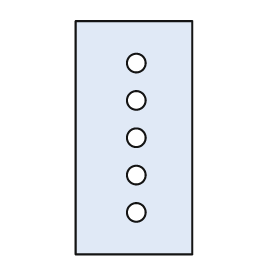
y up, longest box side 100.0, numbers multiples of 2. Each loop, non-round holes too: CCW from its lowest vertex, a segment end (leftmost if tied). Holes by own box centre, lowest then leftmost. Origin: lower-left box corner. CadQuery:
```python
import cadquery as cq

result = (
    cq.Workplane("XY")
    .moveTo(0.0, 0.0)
    .lineTo(50.0, 0.0)
    .lineTo(50.0, 100.0)
    .lineTo(0.0, 100.0)
    .close()
    .moveTo(26.0, 18.0)
    .circle(4.0)
    .moveTo(26.0, 34.0)
    .circle(4.0)
    .moveTo(26.0, 50.0)
    .circle(4.0)
    .moveTo(26.0, 66.0)
    .circle(4.0)
    .moveTo(26.0, 82.0)
    .circle(4.0)
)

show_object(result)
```